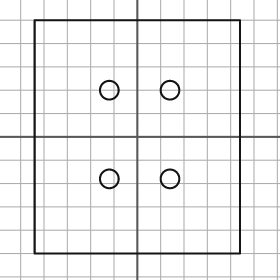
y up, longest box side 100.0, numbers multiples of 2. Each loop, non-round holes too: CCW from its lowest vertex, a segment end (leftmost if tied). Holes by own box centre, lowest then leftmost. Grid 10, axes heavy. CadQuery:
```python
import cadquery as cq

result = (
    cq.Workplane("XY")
    .moveTo(-44.0, -50.0)
    .lineTo(44.0, -50.0)
    .lineTo(44.0, 50.0)
    .lineTo(-44.0, 50.0)
    .close()
    .moveTo(-12.0, -18.0)
    .circle(4.0)
    .moveTo(14.0, -18.0)
    .circle(4.0)
    .moveTo(-12.0, 20.0)
    .circle(4.0)
    .moveTo(14.0, 20.0)
    .circle(4.0)
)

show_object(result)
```